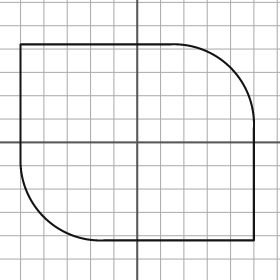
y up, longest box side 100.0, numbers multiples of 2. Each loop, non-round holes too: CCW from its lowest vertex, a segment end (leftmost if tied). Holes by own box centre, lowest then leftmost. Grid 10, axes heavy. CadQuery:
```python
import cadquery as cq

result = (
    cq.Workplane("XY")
    .moveTo(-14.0, -42.0)
    .lineTo(50.0, -42.0)
    .lineTo(50.0, 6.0)
    .threePointArc((40.0, 32.0), (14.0, 42.0))
    .lineTo(-50.0, 42.0)
    .lineTo(-50.0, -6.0)
    .threePointArc((-40.0, -32.0), (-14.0, -42.0))
    .close()
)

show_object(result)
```